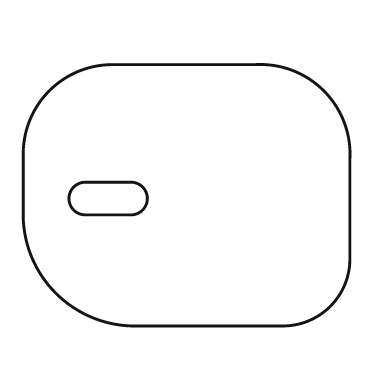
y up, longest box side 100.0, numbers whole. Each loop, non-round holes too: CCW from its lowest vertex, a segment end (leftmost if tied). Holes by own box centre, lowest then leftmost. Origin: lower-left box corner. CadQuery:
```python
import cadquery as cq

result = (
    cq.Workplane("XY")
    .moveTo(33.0, 0.0)
    .lineTo(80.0, 0.0)
    .threePointArc((94.0, 6.0), (100.0, 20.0))
    .lineTo(100.0, 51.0)
    .threePointArc((92.0, 72.0), (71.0, 80.0))
    .lineTo(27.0, 80.0)
    .threePointArc((8.0, 72.0), (0.0, 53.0))
    .lineTo(0.0, 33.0)
    .threePointArc((10.0, 10.0), (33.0, 0.0))
    .close()
    .moveTo(19.0, 34.0)
    .lineTo(33.0, 34.0)
    .threePointArc((38.0, 39.0), (33.0, 44.0))
    .lineTo(19.0, 44.0)
    .threePointArc((14.0, 39.0), (19.0, 34.0))
    .close()
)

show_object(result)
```